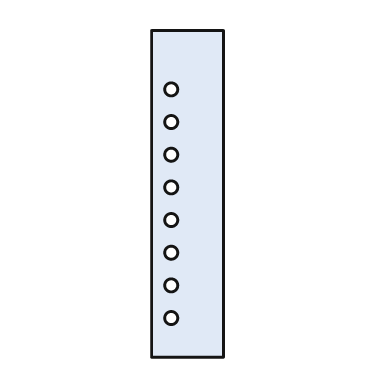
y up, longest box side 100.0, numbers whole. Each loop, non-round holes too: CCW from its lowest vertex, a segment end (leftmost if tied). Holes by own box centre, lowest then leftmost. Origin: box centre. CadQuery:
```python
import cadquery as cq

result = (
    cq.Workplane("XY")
    .moveTo(-11.0, -50.0)
    .lineTo(11.0, -50.0)
    .lineTo(11.0, 50.0)
    .lineTo(-11.0, 50.0)
    .close()
    .moveTo(-5.0, -38.0)
    .circle(2.0)
    .moveTo(-5.0, -28.0)
    .circle(2.0)
    .moveTo(-5.0, -18.0)
    .circle(2.0)
    .moveTo(-5.0, -8.0)
    .circle(2.0)
    .moveTo(-5.0, 2.0)
    .circle(2.0)
    .moveTo(-5.0, 12.0)
    .circle(2.0)
    .moveTo(-5.0, 22.0)
    .circle(2.0)
    .moveTo(-5.0, 32.0)
    .circle(2.0)
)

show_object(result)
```